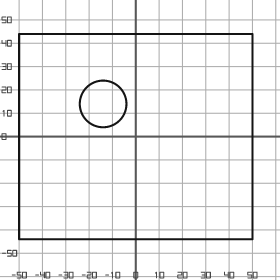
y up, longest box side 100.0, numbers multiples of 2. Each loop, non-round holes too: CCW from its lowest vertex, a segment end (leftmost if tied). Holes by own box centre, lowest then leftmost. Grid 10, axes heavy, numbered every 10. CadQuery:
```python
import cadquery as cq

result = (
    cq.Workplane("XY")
    .moveTo(-50.0, -44.0)
    .lineTo(50.0, -44.0)
    .lineTo(50.0, 44.0)
    .lineTo(-50.0, 44.0)
    .close()
    .moveTo(-14.0, 14.0)
    .circle(10.0)
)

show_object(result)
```